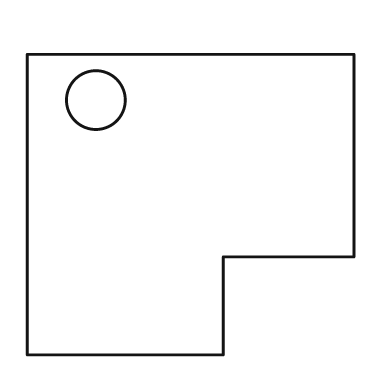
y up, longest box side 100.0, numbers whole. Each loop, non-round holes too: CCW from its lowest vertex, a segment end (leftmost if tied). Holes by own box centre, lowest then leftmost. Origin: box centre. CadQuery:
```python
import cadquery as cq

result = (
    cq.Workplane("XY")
    .moveTo(-50.0, -46.0)
    .lineTo(10.0, -46.0)
    .lineTo(10.0, -16.0)
    .lineTo(50.0, -16.0)
    .lineTo(50.0, 46.0)
    .lineTo(-50.0, 46.0)
    .close()
    .moveTo(-29.0, 32.0)
    .circle(9.0)
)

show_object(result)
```